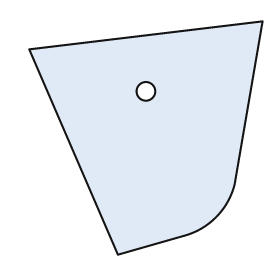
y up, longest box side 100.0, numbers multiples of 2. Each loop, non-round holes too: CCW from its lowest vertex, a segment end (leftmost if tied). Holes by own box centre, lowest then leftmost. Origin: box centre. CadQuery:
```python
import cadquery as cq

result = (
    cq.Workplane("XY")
    .moveTo(-12.0, -50.0)
    .lineTo(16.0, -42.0)
    .threePointArc((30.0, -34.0), (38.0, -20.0))
    .lineTo(50.0, 50.0)
    .lineTo(-50.0, 38.0)
    .close()
    .moveTo(0.0, 20.0)
    .circle(4.0)
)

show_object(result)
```